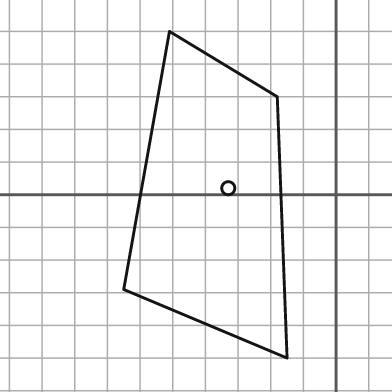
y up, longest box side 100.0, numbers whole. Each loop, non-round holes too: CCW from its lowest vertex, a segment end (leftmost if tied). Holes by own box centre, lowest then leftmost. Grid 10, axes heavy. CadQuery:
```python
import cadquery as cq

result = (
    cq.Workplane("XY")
    .moveTo(-15.0, -50.0)
    .lineTo(-18.0, 30.0)
    .lineTo(-51.0, 50.0)
    .lineTo(-65.0, -29.0)
    .close()
    .moveTo(-33.0, 2.0)
    .circle(2.0)
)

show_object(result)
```